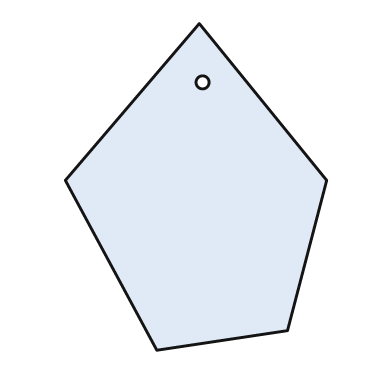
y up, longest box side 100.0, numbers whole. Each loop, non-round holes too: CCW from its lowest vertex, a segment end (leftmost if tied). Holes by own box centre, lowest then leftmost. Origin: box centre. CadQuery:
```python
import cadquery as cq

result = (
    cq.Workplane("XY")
    .moveTo(-12.0, -50.0)
    .lineTo(28.0, -44.0)
    .lineTo(40.0, 2.0)
    .lineTo(1.0, 50.0)
    .lineTo(-40.0, 2.0)
    .close()
    .moveTo(2.0, 32.0)
    .circle(2.0)
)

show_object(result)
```